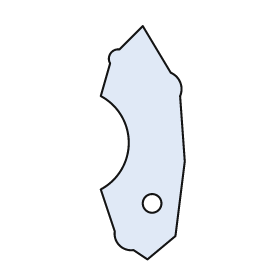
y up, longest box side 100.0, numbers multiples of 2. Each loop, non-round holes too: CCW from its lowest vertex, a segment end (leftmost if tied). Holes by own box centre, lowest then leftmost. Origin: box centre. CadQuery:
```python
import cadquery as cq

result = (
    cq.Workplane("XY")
    .moveTo(2.0, -50.0)
    .lineTo(14.0, -40.0)
    .lineTo(18.0, -8.0)
    .lineTo(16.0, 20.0)
    .threePointArc((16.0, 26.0), (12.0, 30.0))
    .lineTo(0.0, 50.0)
    .lineTo(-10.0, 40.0)
    .threePointArc((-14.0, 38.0), (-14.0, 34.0))
    .lineTo(-18.0, 20.0)
    .threePointArc((-6.0, 0.0), (-18.0, -20.0))
    .lineTo(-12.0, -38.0)
    .threePointArc((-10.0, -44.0), (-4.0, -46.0))
    .close()
    .moveTo(4.0, -26.0)
    .circle(4.0)
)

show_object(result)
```